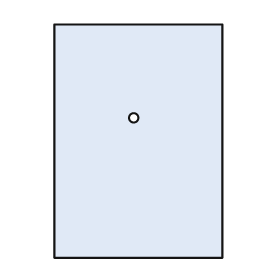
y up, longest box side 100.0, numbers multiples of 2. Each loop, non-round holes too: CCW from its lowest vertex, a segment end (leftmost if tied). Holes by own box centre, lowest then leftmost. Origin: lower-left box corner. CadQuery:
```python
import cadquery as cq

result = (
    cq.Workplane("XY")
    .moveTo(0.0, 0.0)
    .lineTo(72.0, 0.0)
    .lineTo(72.0, 100.0)
    .lineTo(0.0, 100.0)
    .close()
    .moveTo(34.0, 60.0)
    .circle(2.0)
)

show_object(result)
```